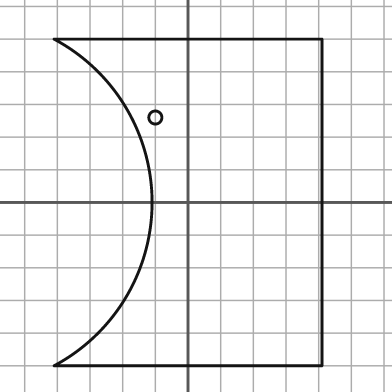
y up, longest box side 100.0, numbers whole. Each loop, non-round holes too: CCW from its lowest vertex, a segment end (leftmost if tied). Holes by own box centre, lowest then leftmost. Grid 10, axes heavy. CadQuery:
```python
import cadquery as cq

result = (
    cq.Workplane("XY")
    .moveTo(-41.0, -50.0)
    .lineTo(41.0, -50.0)
    .lineTo(41.0, 50.0)
    .lineTo(-41.0, 50.0)
    .threePointArc((-11.0, 0.0), (-41.0, -50.0))
    .close()
    .moveTo(-10.0, 26.0)
    .circle(2.0)
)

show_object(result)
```